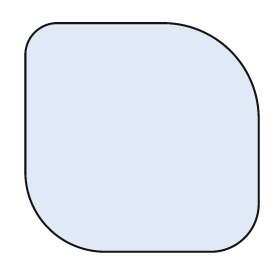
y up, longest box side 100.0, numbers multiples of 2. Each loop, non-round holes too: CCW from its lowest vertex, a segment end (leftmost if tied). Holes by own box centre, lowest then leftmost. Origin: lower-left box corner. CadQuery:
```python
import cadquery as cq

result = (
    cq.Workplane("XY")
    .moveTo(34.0, 0.0)
    .lineTo(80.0, 0.0)
    .threePointArc((94.0, 6.0), (100.0, 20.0))
    .lineTo(100.0, 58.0)
    .threePointArc((88.0, 86.0), (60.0, 98.0))
    .lineTo(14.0, 98.0)
    .threePointArc((4.0, 94.0), (0.0, 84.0))
    .lineTo(0.0, 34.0)
    .threePointArc((10.0, 10.0), (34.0, 0.0))
    .close()
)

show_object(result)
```